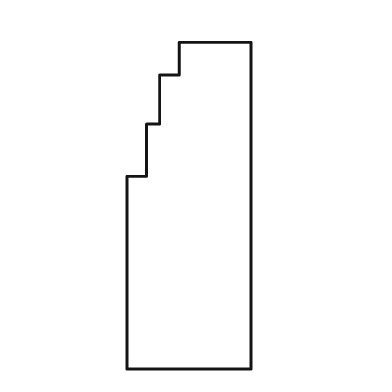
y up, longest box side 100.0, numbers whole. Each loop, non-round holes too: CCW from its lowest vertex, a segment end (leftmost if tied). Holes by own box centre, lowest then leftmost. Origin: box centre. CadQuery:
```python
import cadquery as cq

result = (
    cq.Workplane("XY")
    .moveTo(-19.0, -50.0)
    .lineTo(19.0, -50.0)
    .lineTo(19.0, 50.0)
    .lineTo(-3.0, 50.0)
    .lineTo(-3.0, 40.0)
    .lineTo(-9.0, 40.0)
    .lineTo(-9.0, 25.0)
    .lineTo(-13.0, 25.0)
    .lineTo(-13.0, 9.0)
    .lineTo(-19.0, 9.0)
    .close()
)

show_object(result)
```